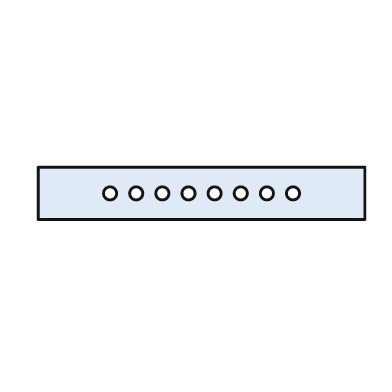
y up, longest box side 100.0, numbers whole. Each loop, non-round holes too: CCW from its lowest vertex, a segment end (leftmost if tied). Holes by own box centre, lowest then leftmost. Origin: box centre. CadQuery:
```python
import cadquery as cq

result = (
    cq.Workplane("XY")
    .moveTo(-50.0, -8.0)
    .lineTo(50.0, -8.0)
    .lineTo(50.0, 8.0)
    .lineTo(-50.0, 8.0)
    .close()
    .moveTo(-28.0, 0.0)
    .circle(2.0)
    .moveTo(-20.0, 0.0)
    .circle(2.0)
    .moveTo(-12.0, 0.0)
    .circle(2.0)
    .moveTo(-4.0, 0.0)
    .circle(2.0)
    .moveTo(4.0, 0.0)
    .circle(2.0)
    .moveTo(12.0, 0.0)
    .circle(2.0)
    .moveTo(20.0, 0.0)
    .circle(2.0)
    .moveTo(28.0, 0.0)
    .circle(2.0)
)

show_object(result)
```